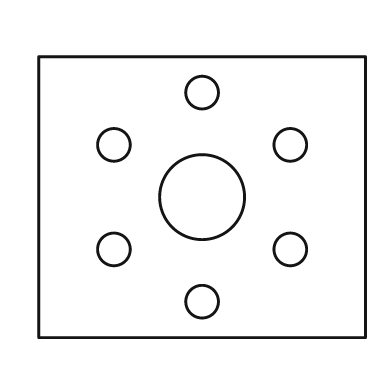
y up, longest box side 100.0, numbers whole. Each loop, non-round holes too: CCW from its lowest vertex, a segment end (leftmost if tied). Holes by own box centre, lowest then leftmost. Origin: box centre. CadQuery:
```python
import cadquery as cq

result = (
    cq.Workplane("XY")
    .moveTo(-50.0, -43.0)
    .lineTo(50.0, -43.0)
    .lineTo(50.0, 43.0)
    .lineTo(-50.0, 43.0)
    .close()
    .moveTo(0.0, -32.0)
    .circle(5.0)
    .moveTo(-27.0, -16.0)
    .circle(5.0)
    .moveTo(27.0, -16.0)
    .circle(5.0)
    .moveTo(0.0, 0.0)
    .circle(13.0)
    .moveTo(-27.0, 16.0)
    .circle(5.0)
    .moveTo(27.0, 16.0)
    .circle(5.0)
    .moveTo(0.0, 32.0)
    .circle(5.0)
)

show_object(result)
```